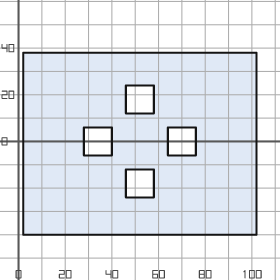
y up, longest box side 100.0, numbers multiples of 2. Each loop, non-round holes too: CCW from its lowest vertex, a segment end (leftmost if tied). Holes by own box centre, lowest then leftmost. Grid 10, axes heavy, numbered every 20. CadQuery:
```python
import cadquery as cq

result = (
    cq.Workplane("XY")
    .moveTo(2.0, -40.0)
    .lineTo(102.0, -40.0)
    .lineTo(102.0, 38.0)
    .lineTo(2.0, 38.0)
    .close()
    .moveTo(46.0, -24.0)
    .lineTo(58.0, -24.0)
    .lineTo(58.0, -12.0)
    .lineTo(46.0, -12.0)
    .close()
    .moveTo(28.0, -6.0)
    .lineTo(40.0, -6.0)
    .lineTo(40.0, 6.0)
    .lineTo(28.0, 6.0)
    .close()
    .moveTo(64.0, -6.0)
    .lineTo(76.0, -6.0)
    .lineTo(76.0, 6.0)
    .lineTo(64.0, 6.0)
    .close()
    .moveTo(46.0, 12.0)
    .lineTo(58.0, 12.0)
    .lineTo(58.0, 24.0)
    .lineTo(46.0, 24.0)
    .close()
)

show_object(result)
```